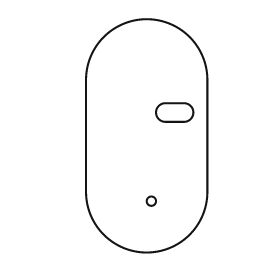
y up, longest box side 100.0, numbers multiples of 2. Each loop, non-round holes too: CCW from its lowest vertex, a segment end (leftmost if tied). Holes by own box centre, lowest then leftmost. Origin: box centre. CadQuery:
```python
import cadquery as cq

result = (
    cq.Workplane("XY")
    .moveTo(-26.0, -24.0)
    .threePointArc((0.0, -50.0), (26.0, -24.0))
    .lineTo(26.0, 24.0)
    .threePointArc((0.0, 50.0), (-26.0, 24.0))
    .close()
    .moveTo(2.0, -28.0)
    .circle(2.0)
    .moveTo(8.0, 6.0)
    .lineTo(16.0, 6.0)
    .threePointArc((20.0, 10.0), (16.0, 14.0))
    .lineTo(8.0, 14.0)
    .threePointArc((4.0, 10.0), (8.0, 6.0))
    .close()
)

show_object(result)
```